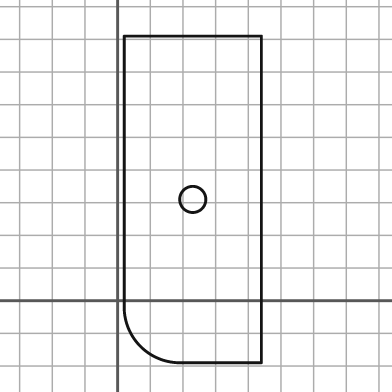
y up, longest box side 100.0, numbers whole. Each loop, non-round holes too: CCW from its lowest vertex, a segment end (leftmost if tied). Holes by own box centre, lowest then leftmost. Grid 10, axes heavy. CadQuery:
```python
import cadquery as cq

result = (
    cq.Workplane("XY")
    .moveTo(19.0, -19.0)
    .lineTo(44.0, -19.0)
    .lineTo(44.0, 81.0)
    .lineTo(2.0, 81.0)
    .lineTo(2.0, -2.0)
    .threePointArc((7.0, -14.0), (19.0, -19.0))
    .close()
    .moveTo(23.0, 31.0)
    .circle(4.0)
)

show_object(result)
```